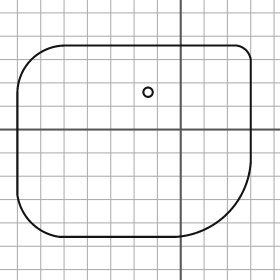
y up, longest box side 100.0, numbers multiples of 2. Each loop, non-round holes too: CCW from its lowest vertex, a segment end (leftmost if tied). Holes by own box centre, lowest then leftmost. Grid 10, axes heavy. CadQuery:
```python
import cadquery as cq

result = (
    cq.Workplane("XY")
    .moveTo(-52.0, -46.0)
    .lineTo(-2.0, -46.0)
    .threePointArc((20.0, -36.0), (30.0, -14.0))
    .lineTo(30.0, 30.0)
    .threePointArc((28.0, 34.0), (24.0, 36.0))
    .lineTo(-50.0, 36.0)
    .threePointArc((-64.0, 30.0), (-70.0, 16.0))
    .lineTo(-70.0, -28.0)
    .threePointArc((-64.0, -40.0), (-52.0, -46.0))
    .close()
    .moveTo(-14.0, 16.0)
    .circle(2.0)
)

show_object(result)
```